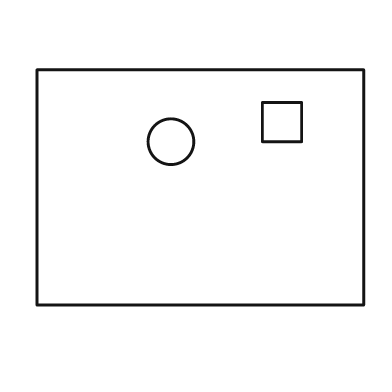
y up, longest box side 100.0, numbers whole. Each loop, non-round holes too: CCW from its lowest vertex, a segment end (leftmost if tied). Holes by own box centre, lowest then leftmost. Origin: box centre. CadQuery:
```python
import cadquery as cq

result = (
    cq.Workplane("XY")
    .moveTo(-50.0, -36.0)
    .lineTo(50.0, -36.0)
    .lineTo(50.0, 36.0)
    .lineTo(-50.0, 36.0)
    .close()
    .moveTo(-9.0, 14.0)
    .circle(7.0)
    .moveTo(19.0, 14.0)
    .lineTo(31.0, 14.0)
    .lineTo(31.0, 26.0)
    .lineTo(19.0, 26.0)
    .close()
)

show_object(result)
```